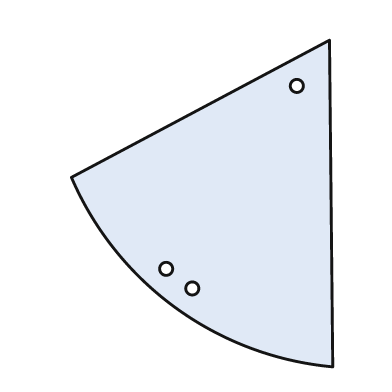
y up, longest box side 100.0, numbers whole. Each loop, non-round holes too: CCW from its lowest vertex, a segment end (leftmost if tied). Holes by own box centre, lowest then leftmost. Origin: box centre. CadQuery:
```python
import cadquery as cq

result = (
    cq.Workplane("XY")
    .moveTo(40.0, -50.0)
    .lineTo(39.0, 50.0)
    .lineTo(-40.0, 8.0)
    .threePointArc((-8.0, -32.0), (40.0, -50.0))
    .close()
    .moveTo(-3.0, -26.0)
    .circle(2.0)
    .moveTo(-11.0, -20.0)
    .circle(2.0)
    .moveTo(29.0, 36.0)
    .circle(2.0)
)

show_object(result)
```